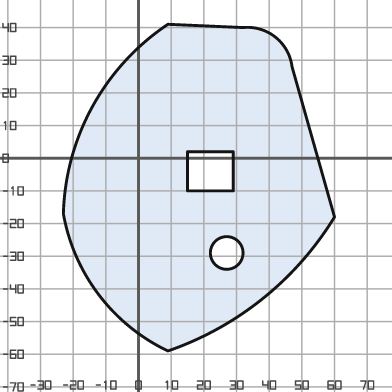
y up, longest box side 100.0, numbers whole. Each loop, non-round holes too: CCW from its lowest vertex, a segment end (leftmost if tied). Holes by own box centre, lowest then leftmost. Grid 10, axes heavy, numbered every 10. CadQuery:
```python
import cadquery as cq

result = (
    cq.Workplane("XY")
    .moveTo(9.0, -59.0)
    .threePointArc((38.0, -43.0), (60.0, -18.0))
    .lineTo(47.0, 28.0)
    .threePointArc((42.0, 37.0), (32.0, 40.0))
    .lineTo(9.0, 41.0)
    .threePointArc((-14.0, 16.0), (-23.0, -17.0))
    .threePointArc((-12.0, -42.0), (9.0, -59.0))
    .close()
    .moveTo(27.0, -29.0)
    .circle(5.0)
    .moveTo(15.0, -10.0)
    .lineTo(29.0, -10.0)
    .lineTo(29.0, 2.0)
    .lineTo(15.0, 2.0)
    .close()
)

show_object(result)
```